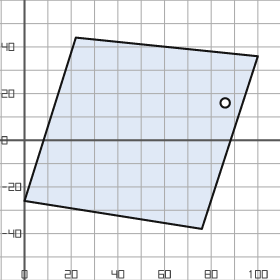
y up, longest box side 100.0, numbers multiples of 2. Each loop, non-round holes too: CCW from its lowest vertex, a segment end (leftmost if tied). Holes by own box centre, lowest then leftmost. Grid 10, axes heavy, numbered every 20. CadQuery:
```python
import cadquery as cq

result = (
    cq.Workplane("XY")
    .moveTo(76.0, -38.0)
    .lineTo(100.0, 36.0)
    .lineTo(22.0, 44.0)
    .lineTo(0.0, -26.0)
    .close()
    .moveTo(86.0, 16.0)
    .circle(2.0)
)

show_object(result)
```